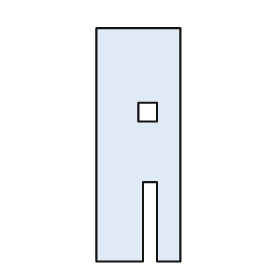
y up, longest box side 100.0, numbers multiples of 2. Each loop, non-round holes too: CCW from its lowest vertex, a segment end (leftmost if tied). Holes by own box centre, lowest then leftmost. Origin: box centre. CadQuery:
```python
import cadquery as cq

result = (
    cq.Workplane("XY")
    .moveTo(-18.0, -50.0)
    .lineTo(2.0, -50.0)
    .lineTo(2.0, -16.0)
    .lineTo(8.0, -16.0)
    .lineTo(8.0, -50.0)
    .lineTo(18.0, -50.0)
    .lineTo(18.0, 50.0)
    .lineTo(-18.0, 50.0)
    .close()
    .moveTo(0.0, 10.0)
    .lineTo(8.0, 10.0)
    .lineTo(8.0, 18.0)
    .lineTo(0.0, 18.0)
    .close()
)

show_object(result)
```